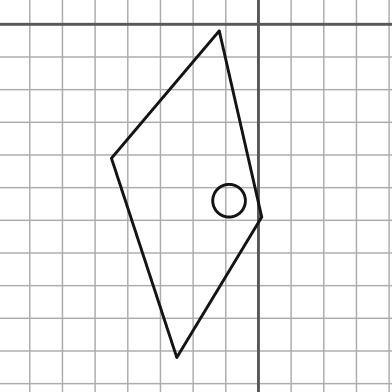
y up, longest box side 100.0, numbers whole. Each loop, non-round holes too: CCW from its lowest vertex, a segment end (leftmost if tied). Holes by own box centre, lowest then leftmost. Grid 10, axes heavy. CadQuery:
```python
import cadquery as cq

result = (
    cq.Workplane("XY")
    .moveTo(-25.0, -102.0)
    .lineTo(1.0, -59.0)
    .lineTo(-12.0, -2.0)
    .lineTo(-45.0, -41.0)
    .close()
    .moveTo(-9.0, -54.0)
    .circle(5.0)
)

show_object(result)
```